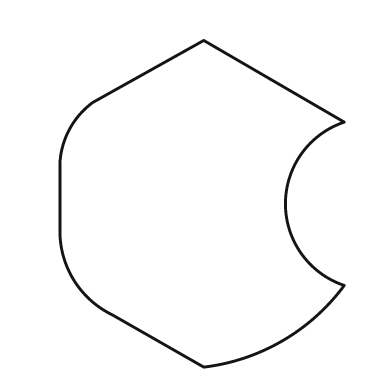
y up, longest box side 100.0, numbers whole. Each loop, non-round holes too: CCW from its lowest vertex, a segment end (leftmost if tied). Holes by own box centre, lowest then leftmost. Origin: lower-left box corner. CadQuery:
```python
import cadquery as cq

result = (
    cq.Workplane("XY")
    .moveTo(44.0, 0.0)
    .threePointArc((68.0, 8.0), (87.0, 25.0))
    .threePointArc((69.0, 50.0), (87.0, 75.0))
    .lineTo(44.0, 100.0)
    .lineTo(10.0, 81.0)
    .threePointArc((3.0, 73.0), (0.0, 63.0))
    .lineTo(0.0, 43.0)
    .threePointArc((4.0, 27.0), (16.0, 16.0))
    .close()
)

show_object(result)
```